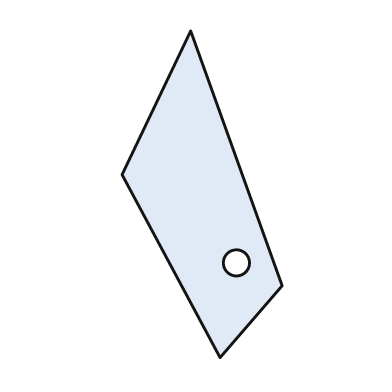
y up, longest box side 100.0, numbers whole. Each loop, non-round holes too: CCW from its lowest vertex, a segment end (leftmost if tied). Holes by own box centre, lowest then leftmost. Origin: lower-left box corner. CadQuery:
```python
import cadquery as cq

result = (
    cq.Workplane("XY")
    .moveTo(30.0, 0.0)
    .lineTo(49.0, 22.0)
    .lineTo(21.0, 100.0)
    .lineTo(0.0, 56.0)
    .close()
    .moveTo(35.0, 29.0)
    .circle(4.0)
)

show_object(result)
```